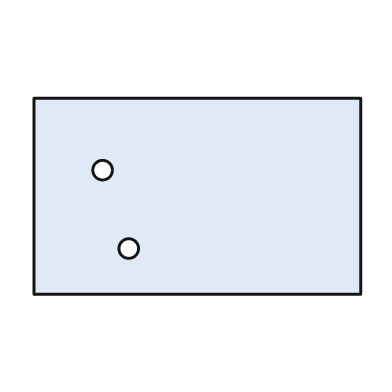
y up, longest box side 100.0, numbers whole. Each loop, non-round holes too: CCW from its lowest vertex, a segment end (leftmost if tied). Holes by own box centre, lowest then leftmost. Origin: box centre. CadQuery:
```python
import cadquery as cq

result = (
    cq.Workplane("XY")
    .moveTo(-50.0, -30.0)
    .lineTo(50.0, -30.0)
    .lineTo(50.0, 30.0)
    .lineTo(-50.0, 30.0)
    .close()
    .moveTo(-21.0, -16.0)
    .circle(3.0)
    .moveTo(-29.0, 8.0)
    .circle(3.0)
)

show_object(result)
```